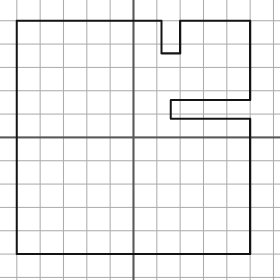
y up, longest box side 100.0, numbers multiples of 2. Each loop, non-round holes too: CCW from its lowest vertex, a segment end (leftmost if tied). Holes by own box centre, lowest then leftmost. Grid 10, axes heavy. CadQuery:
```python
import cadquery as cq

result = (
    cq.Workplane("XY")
    .moveTo(-50.0, -50.0)
    .lineTo(50.0, -50.0)
    .lineTo(50.0, 8.0)
    .lineTo(16.0, 8.0)
    .lineTo(16.0, 16.0)
    .lineTo(50.0, 16.0)
    .lineTo(50.0, 50.0)
    .lineTo(20.0, 50.0)
    .lineTo(20.0, 36.0)
    .lineTo(12.0, 36.0)
    .lineTo(12.0, 50.0)
    .lineTo(-50.0, 50.0)
    .close()
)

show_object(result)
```